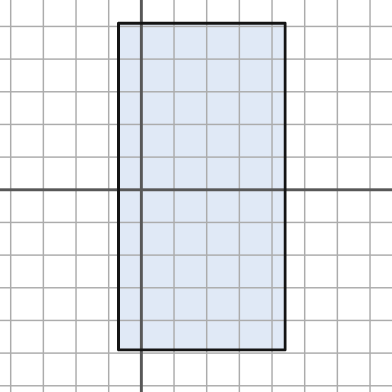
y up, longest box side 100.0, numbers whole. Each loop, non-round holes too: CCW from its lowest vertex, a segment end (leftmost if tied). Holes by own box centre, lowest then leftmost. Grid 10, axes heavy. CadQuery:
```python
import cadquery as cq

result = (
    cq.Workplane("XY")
    .moveTo(-7.0, -49.0)
    .lineTo(44.0, -49.0)
    .lineTo(44.0, 51.0)
    .lineTo(-7.0, 51.0)
    .close()
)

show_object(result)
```